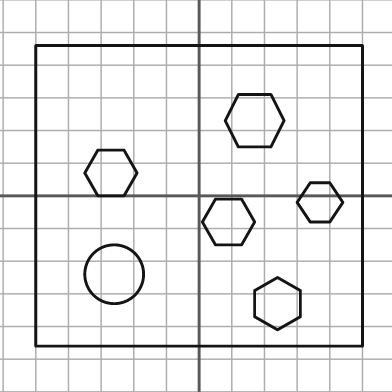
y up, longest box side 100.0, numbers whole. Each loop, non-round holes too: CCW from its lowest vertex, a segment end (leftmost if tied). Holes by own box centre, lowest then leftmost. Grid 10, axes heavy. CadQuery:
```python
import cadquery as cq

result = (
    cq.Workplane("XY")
    .moveTo(-50.0, -46.0)
    .lineTo(50.0, -46.0)
    .lineTo(50.0, 46.0)
    .lineTo(-50.0, 46.0)
    .close()
    .moveTo(24.0, -41.0)
    .lineTo(31.0, -37.0)
    .lineTo(31.0, -29.0)
    .lineTo(24.0, -25.0)
    .lineTo(17.0, -29.0)
    .lineTo(17.0, -37.0)
    .close()
    .moveTo(-26.0, -24.0)
    .circle(9.0)
    .moveTo(5.0, -15.0)
    .lineTo(13.0, -15.0)
    .lineTo(17.0, -8.0)
    .lineTo(13.0, -1.0)
    .lineTo(5.0, -1.0)
    .lineTo(1.0, -8.0)
    .close()
    .moveTo(34.0, -8.0)
    .lineTo(40.0, -8.0)
    .lineTo(44.0, -2.0)
    .lineTo(40.0, 4.0)
    .lineTo(34.0, 4.0)
    .lineTo(30.0, -2.0)
    .close()
    .moveTo(-31.0, 0.0)
    .lineTo(-23.0, 0.0)
    .lineTo(-19.0, 7.0)
    .lineTo(-23.0, 14.0)
    .lineTo(-31.0, 14.0)
    .lineTo(-35.0, 7.0)
    .close()
    .moveTo(12.0, 15.0)
    .lineTo(22.0, 15.0)
    .lineTo(26.0, 23.0)
    .lineTo(22.0, 31.0)
    .lineTo(12.0, 31.0)
    .lineTo(8.0, 23.0)
    .close()
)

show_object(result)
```